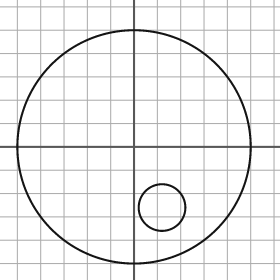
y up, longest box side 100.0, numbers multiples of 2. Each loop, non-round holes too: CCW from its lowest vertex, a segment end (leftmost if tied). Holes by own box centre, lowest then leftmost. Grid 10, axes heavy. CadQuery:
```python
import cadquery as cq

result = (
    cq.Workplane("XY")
    .moveTo(0.0, 0.0)
    .circle(50.0)
    .moveTo(12.0, -26.0)
    .circle(10.0)
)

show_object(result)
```